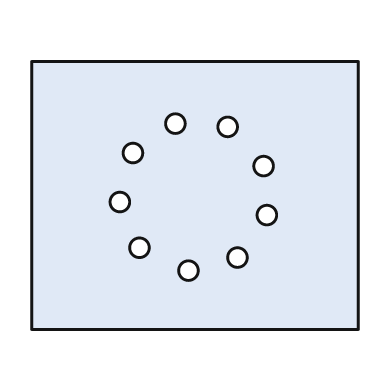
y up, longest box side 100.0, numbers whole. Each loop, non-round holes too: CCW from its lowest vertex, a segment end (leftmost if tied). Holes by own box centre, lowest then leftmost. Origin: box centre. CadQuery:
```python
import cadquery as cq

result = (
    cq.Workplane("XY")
    .moveTo(-50.0, -41.0)
    .lineTo(50.0, -41.0)
    .lineTo(50.0, 41.0)
    .lineTo(-50.0, 41.0)
    .close()
    .moveTo(-2.0, -23.0)
    .circle(3.0)
    .moveTo(13.0, -19.0)
    .circle(3.0)
    .moveTo(-17.0, -16.0)
    .circle(3.0)
    .moveTo(22.0, -6.0)
    .circle(3.0)
    .moveTo(-23.0, -2.0)
    .circle(3.0)
    .moveTo(21.0, 9.0)
    .circle(3.0)
    .moveTo(-19.0, 13.0)
    .circle(3.0)
    .moveTo(10.0, 21.0)
    .circle(3.0)
    .moveTo(-6.0, 22.0)
    .circle(3.0)
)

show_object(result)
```